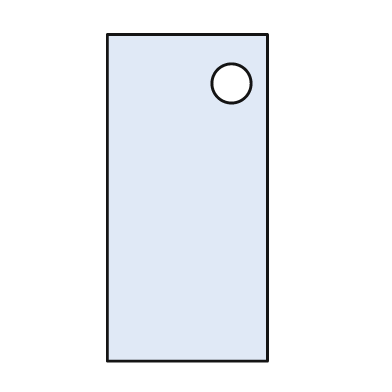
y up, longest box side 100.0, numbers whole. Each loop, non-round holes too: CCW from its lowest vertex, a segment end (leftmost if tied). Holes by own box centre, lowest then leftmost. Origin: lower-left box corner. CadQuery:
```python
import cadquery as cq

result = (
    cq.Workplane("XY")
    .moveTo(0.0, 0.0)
    .lineTo(49.0, 0.0)
    .lineTo(49.0, 100.0)
    .lineTo(0.0, 100.0)
    .close()
    .moveTo(38.0, 85.0)
    .circle(6.0)
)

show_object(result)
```